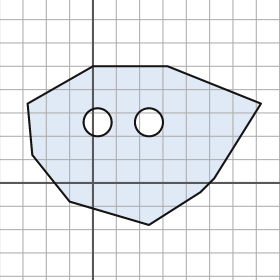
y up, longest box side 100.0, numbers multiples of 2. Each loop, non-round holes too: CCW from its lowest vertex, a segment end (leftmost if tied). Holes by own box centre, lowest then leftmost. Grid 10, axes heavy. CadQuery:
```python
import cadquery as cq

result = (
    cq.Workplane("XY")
    .moveTo(24.0, -18.0)
    .lineTo(46.0, -4.0)
    .lineTo(52.0, 2.0)
    .lineTo(72.0, 34.0)
    .lineTo(32.0, 50.0)
    .lineTo(0.0, 50.0)
    .lineTo(-28.0, 34.0)
    .lineTo(-26.0, 12.0)
    .lineTo(-10.0, -8.0)
    .close()
    .moveTo(2.0, 26.0)
    .circle(6.0)
    .moveTo(24.0, 26.0)
    .circle(6.0)
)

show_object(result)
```